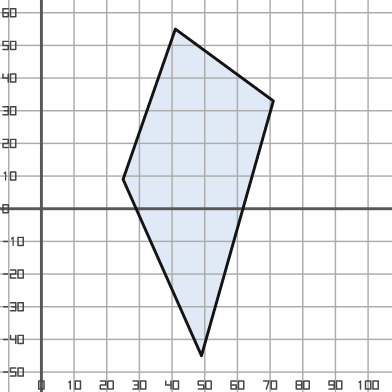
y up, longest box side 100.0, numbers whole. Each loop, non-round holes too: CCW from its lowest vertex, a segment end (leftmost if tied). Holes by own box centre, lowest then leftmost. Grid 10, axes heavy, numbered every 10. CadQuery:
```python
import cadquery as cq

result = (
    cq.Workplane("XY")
    .moveTo(49.0, -45.0)
    .lineTo(71.0, 33.0)
    .lineTo(41.0, 55.0)
    .lineTo(25.0, 9.0)
    .close()
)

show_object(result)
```